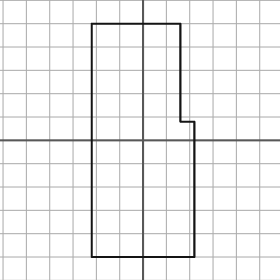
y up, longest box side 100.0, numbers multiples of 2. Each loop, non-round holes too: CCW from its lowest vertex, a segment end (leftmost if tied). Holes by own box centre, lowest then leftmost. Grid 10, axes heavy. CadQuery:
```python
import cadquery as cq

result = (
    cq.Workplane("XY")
    .moveTo(-22.0, -50.0)
    .lineTo(22.0, -50.0)
    .lineTo(22.0, 8.0)
    .lineTo(16.0, 8.0)
    .lineTo(16.0, 50.0)
    .lineTo(-22.0, 50.0)
    .close()
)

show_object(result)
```